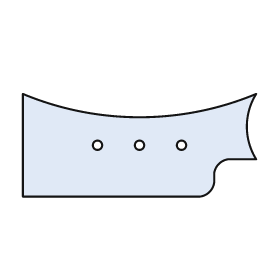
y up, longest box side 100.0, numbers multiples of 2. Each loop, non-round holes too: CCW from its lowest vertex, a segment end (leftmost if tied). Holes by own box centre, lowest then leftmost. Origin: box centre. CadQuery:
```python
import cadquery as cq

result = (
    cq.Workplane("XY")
    .moveTo(-50.0, -22.0)
    .lineTo(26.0, -22.0)
    .threePointArc((30.0, -20.0), (32.0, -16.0))
    .lineTo(32.0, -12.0)
    .threePointArc((34.0, -8.0), (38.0, -6.0))
    .lineTo(50.0, -6.0)
    .threePointArc((46.0, 8.0), (50.0, 22.0))
    .threePointArc((0.0, 12.0), (-50.0, 22.0))
    .close()
    .moveTo(-18.0, 0.0)
    .circle(2.0)
    .moveTo(0.0, 0.0)
    .circle(2.0)
    .moveTo(18.0, 0.0)
    .circle(2.0)
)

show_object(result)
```